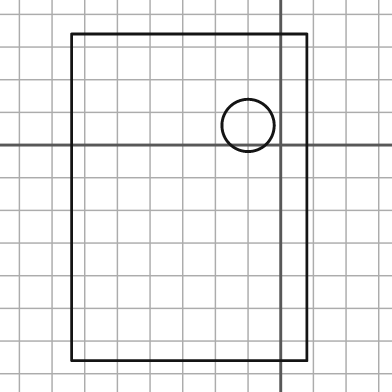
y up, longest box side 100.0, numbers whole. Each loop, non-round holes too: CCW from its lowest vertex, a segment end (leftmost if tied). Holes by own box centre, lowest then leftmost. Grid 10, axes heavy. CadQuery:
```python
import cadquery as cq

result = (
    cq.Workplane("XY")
    .moveTo(-64.0, -66.0)
    .lineTo(8.0, -66.0)
    .lineTo(8.0, 34.0)
    .lineTo(-64.0, 34.0)
    .close()
    .moveTo(-10.0, 6.0)
    .circle(8.0)
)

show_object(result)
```